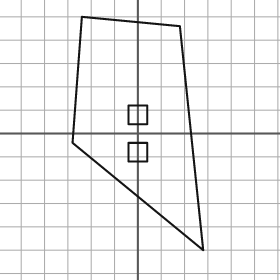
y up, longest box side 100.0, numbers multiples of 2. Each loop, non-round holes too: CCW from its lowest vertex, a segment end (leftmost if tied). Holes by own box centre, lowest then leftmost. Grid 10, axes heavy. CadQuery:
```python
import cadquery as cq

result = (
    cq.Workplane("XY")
    .moveTo(28.0, -50.0)
    .lineTo(18.0, 46.0)
    .lineTo(-24.0, 50.0)
    .lineTo(-28.0, -4.0)
    .close()
    .moveTo(-4.0, -12.0)
    .lineTo(4.0, -12.0)
    .lineTo(4.0, -4.0)
    .lineTo(-4.0, -4.0)
    .close()
    .moveTo(-4.0, 4.0)
    .lineTo(4.0, 4.0)
    .lineTo(4.0, 12.0)
    .lineTo(-4.0, 12.0)
    .close()
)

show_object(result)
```